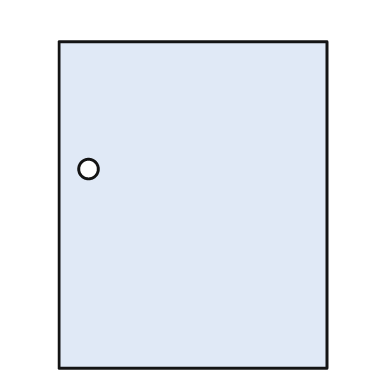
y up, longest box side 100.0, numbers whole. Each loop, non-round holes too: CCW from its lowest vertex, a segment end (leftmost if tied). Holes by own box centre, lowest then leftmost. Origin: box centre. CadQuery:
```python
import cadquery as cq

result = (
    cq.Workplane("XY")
    .moveTo(-41.0, -50.0)
    .lineTo(41.0, -50.0)
    .lineTo(41.0, 50.0)
    .lineTo(-41.0, 50.0)
    .close()
    .moveTo(-32.0, 11.0)
    .circle(3.0)
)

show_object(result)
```